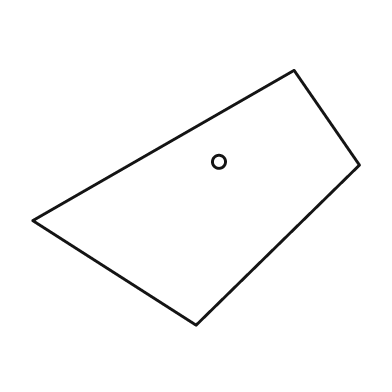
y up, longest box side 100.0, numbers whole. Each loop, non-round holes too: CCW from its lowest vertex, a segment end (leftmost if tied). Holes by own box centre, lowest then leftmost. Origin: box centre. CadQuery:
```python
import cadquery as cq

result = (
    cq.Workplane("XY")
    .moveTo(0.0, -39.0)
    .lineTo(50.0, 10.0)
    .lineTo(30.0, 39.0)
    .lineTo(-50.0, -7.0)
    .close()
    .moveTo(7.0, 11.0)
    .circle(2.0)
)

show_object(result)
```